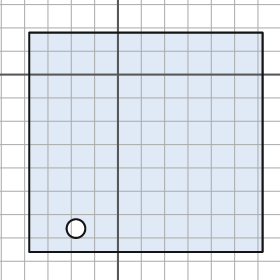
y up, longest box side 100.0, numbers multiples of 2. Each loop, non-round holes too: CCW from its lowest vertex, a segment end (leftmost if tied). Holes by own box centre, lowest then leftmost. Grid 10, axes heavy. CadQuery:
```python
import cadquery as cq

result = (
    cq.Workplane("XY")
    .moveTo(-38.0, -76.0)
    .lineTo(62.0, -76.0)
    .lineTo(62.0, 18.0)
    .lineTo(-38.0, 18.0)
    .close()
    .moveTo(-18.0, -66.0)
    .circle(4.0)
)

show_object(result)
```